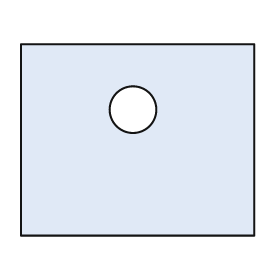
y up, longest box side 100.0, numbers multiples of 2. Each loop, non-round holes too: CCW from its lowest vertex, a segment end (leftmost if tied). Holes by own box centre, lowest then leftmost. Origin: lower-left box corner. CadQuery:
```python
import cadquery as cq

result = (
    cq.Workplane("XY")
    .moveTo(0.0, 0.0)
    .lineTo(100.0, 0.0)
    .lineTo(100.0, 82.0)
    .lineTo(0.0, 82.0)
    .close()
    .moveTo(48.0, 54.0)
    .circle(10.0)
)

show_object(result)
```